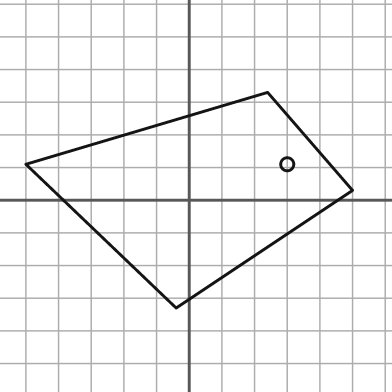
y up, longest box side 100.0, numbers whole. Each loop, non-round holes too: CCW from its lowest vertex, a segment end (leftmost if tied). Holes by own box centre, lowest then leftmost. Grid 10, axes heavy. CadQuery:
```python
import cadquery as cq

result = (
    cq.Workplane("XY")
    .moveTo(-4.0, -33.0)
    .lineTo(50.0, 3.0)
    .lineTo(24.0, 33.0)
    .lineTo(-50.0, 11.0)
    .close()
    .moveTo(30.0, 11.0)
    .circle(2.0)
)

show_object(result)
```